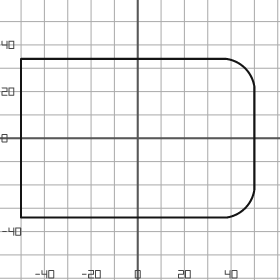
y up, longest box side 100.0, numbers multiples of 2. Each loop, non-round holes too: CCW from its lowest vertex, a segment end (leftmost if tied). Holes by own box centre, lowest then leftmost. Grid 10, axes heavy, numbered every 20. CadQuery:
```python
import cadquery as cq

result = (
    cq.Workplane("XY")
    .moveTo(-50.0, -34.0)
    .lineTo(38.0, -34.0)
    .threePointArc((46.0, -30.0), (50.0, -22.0))
    .lineTo(50.0, 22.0)
    .threePointArc((46.0, 30.0), (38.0, 34.0))
    .lineTo(-50.0, 34.0)
    .close()
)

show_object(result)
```